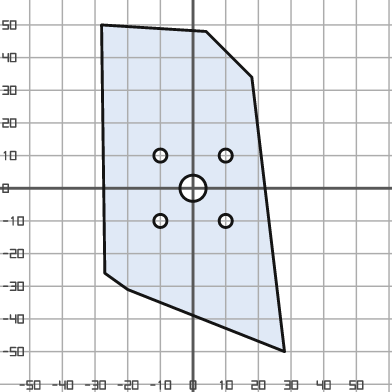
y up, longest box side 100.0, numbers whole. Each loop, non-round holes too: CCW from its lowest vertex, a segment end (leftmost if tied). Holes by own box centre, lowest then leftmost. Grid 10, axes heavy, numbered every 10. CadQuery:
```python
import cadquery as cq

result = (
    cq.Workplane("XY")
    .moveTo(28.0, -50.0)
    .lineTo(18.0, 34.0)
    .lineTo(4.0, 48.0)
    .lineTo(-28.0, 50.0)
    .lineTo(-27.0, -26.0)
    .lineTo(-20.0, -31.0)
    .close()
    .moveTo(-10.0, -10.0)
    .circle(2.0)
    .moveTo(10.0, -10.0)
    .circle(2.0)
    .moveTo(0.0, 0.0)
    .circle(4.0)
    .moveTo(-10.0, 10.0)
    .circle(2.0)
    .moveTo(10.0, 10.0)
    .circle(2.0)
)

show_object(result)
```